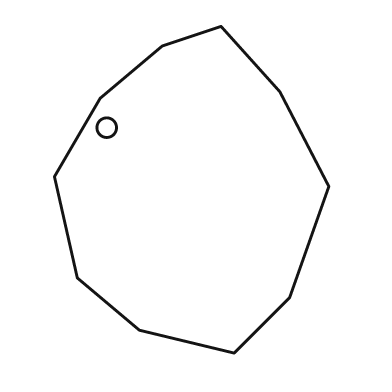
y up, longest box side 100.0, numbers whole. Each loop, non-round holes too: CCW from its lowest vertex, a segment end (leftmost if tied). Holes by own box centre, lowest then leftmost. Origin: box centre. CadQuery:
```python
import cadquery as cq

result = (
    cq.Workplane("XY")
    .moveTo(13.0, -50.0)
    .lineTo(30.0, -33.0)
    .lineTo(42.0, 1.0)
    .lineTo(27.0, 30.0)
    .lineTo(9.0, 50.0)
    .lineTo(-9.0, 44.0)
    .lineTo(-28.0, 28.0)
    .lineTo(-42.0, 4.0)
    .lineTo(-35.0, -27.0)
    .lineTo(-16.0, -43.0)
    .close()
    .moveTo(-26.0, 19.0)
    .circle(3.0)
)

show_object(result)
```